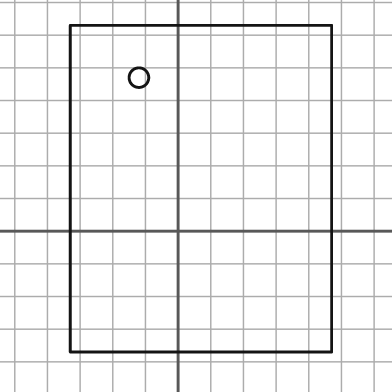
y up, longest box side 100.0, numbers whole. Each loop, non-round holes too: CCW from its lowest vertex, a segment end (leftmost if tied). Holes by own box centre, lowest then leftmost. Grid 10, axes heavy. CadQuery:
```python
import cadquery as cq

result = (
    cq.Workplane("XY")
    .moveTo(-33.0, -37.0)
    .lineTo(47.0, -37.0)
    .lineTo(47.0, 63.0)
    .lineTo(-33.0, 63.0)
    .close()
    .moveTo(-12.0, 47.0)
    .circle(3.0)
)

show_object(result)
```